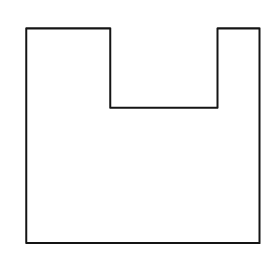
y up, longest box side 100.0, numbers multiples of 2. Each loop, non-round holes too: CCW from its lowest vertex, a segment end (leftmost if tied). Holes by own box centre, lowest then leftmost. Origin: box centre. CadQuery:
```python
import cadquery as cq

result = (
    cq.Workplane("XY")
    .moveTo(-50.0, -46.0)
    .lineTo(50.0, -46.0)
    .lineTo(50.0, 46.0)
    .lineTo(32.0, 46.0)
    .lineTo(32.0, 12.0)
    .lineTo(-14.0, 12.0)
    .lineTo(-14.0, 46.0)
    .lineTo(-50.0, 46.0)
    .close()
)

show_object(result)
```